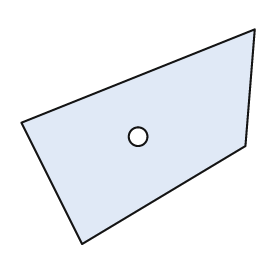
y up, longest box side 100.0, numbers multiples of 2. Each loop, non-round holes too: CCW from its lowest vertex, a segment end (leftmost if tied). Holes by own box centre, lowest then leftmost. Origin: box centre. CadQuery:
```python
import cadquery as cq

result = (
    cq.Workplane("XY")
    .moveTo(-24.0, -46.0)
    .lineTo(46.0, -4.0)
    .lineTo(50.0, 46.0)
    .lineTo(-50.0, 6.0)
    .close()
    .moveTo(0.0, 0.0)
    .circle(4.0)
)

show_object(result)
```